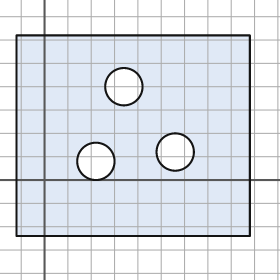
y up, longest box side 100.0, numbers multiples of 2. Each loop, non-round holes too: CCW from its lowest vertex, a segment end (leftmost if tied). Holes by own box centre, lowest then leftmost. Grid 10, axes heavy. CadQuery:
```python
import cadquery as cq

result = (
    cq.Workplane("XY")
    .moveTo(-12.0, -24.0)
    .lineTo(88.0, -24.0)
    .lineTo(88.0, 62.0)
    .lineTo(-12.0, 62.0)
    .close()
    .moveTo(22.0, 8.0)
    .circle(8.0)
    .moveTo(56.0, 12.0)
    .circle(8.0)
    .moveTo(34.0, 40.0)
    .circle(8.0)
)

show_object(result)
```